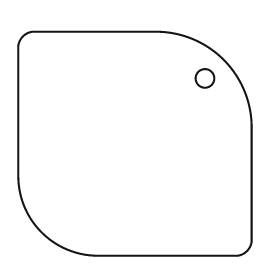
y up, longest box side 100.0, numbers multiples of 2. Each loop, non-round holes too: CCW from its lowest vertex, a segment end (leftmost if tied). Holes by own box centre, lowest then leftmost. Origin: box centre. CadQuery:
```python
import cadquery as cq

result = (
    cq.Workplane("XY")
    .moveTo(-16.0, -48.0)
    .lineTo(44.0, -48.0)
    .threePointArc((48.0, -46.0), (50.0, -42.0))
    .lineTo(50.0, 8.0)
    .threePointArc((38.0, 36.0), (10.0, 48.0))
    .lineTo(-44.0, 48.0)
    .threePointArc((-48.0, 46.0), (-50.0, 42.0))
    .lineTo(-50.0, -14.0)
    .threePointArc((-40.0, -38.0), (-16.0, -48.0))
    .close()
    .moveTo(30.0, 28.0)
    .circle(4.0)
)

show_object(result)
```